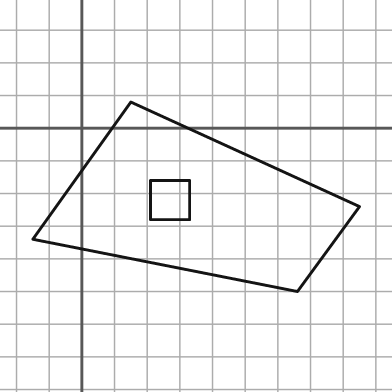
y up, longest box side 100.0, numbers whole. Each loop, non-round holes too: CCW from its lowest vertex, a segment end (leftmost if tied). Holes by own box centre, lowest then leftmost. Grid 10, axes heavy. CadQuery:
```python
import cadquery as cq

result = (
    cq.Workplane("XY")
    .moveTo(66.0, -50.0)
    .lineTo(85.0, -24.0)
    .lineTo(15.0, 8.0)
    .lineTo(-15.0, -34.0)
    .close()
    .moveTo(21.0, -28.0)
    .lineTo(33.0, -28.0)
    .lineTo(33.0, -16.0)
    .lineTo(21.0, -16.0)
    .close()
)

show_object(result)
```